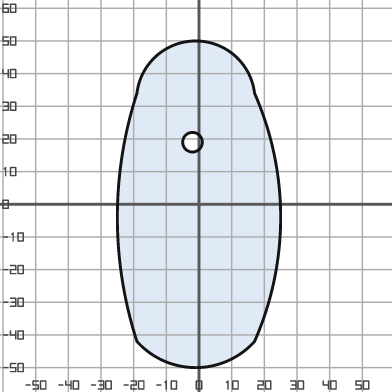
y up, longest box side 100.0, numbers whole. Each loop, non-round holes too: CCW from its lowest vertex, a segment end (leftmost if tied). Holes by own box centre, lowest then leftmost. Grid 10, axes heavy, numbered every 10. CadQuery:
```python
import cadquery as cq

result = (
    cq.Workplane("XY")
    .moveTo(-19.0, -42.0)
    .threePointArc((-1.0, -50.0), (17.0, -42.0))
    .threePointArc((25.0, -4.0), (17.0, 34.0))
    .threePointArc((-1.0, 50.0), (-19.0, 34.0))
    .threePointArc((-25.0, -4.0), (-19.0, -42.0))
    .close()
    .moveTo(-2.0, 19.0)
    .circle(3.0)
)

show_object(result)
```